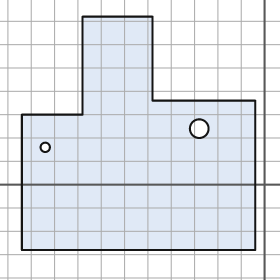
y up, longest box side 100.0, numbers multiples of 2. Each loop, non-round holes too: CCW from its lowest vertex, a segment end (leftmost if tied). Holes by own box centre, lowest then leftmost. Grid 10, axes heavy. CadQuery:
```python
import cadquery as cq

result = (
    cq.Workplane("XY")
    .moveTo(-104.0, -28.0)
    .lineTo(-4.0, -28.0)
    .lineTo(-4.0, 36.0)
    .lineTo(-48.0, 36.0)
    .lineTo(-48.0, 72.0)
    .lineTo(-78.0, 72.0)
    .lineTo(-78.0, 30.0)
    .lineTo(-104.0, 30.0)
    .close()
    .moveTo(-94.0, 16.0)
    .circle(2.0)
    .moveTo(-28.0, 24.0)
    .circle(4.0)
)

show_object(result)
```